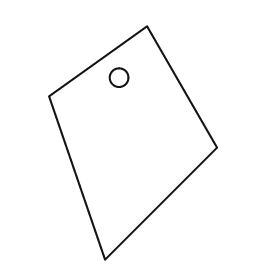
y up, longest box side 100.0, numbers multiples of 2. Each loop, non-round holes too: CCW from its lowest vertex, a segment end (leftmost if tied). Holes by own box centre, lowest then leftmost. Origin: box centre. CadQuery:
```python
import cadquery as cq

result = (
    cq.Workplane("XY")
    .moveTo(-12.0, -50.0)
    .lineTo(36.0, -2.0)
    .lineTo(6.0, 50.0)
    .lineTo(-36.0, 20.0)
    .close()
    .moveTo(-6.0, 28.0)
    .circle(4.0)
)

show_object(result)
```